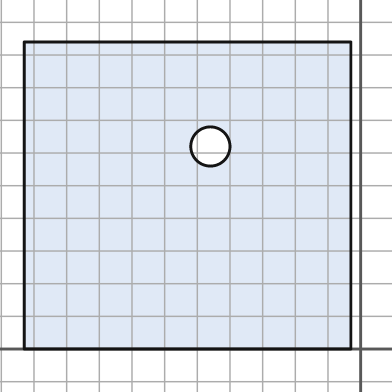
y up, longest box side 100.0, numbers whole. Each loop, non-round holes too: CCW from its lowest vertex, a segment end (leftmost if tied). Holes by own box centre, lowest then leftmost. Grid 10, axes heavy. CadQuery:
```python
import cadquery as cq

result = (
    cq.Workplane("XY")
    .moveTo(-103.0, 0.0)
    .lineTo(-3.0, 0.0)
    .lineTo(-3.0, 94.0)
    .lineTo(-103.0, 94.0)
    .close()
    .moveTo(-46.0, 62.0)
    .circle(6.0)
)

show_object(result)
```